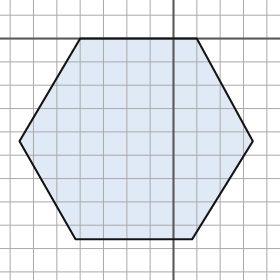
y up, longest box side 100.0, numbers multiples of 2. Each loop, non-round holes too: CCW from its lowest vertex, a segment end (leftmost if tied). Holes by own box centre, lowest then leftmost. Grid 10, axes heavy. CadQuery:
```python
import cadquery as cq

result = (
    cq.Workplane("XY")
    .moveTo(-42.0, -86.0)
    .lineTo(8.0, -86.0)
    .lineTo(34.0, -44.0)
    .lineTo(10.0, 0.0)
    .lineTo(-40.0, 0.0)
    .lineTo(-66.0, -44.0)
    .close()
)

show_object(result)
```